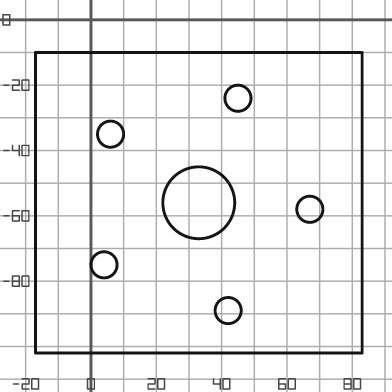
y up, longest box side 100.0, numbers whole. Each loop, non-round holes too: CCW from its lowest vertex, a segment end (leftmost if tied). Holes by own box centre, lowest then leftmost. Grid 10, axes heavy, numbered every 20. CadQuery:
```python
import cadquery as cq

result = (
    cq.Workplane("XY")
    .moveTo(-17.0, -102.0)
    .lineTo(83.0, -102.0)
    .lineTo(83.0, -10.0)
    .lineTo(-17.0, -10.0)
    .close()
    .moveTo(42.0, -89.0)
    .circle(4.0)
    .moveTo(4.0, -75.0)
    .circle(4.0)
    .moveTo(67.0, -58.0)
    .circle(4.0)
    .moveTo(33.0, -56.0)
    .circle(11.0)
    .moveTo(6.0, -35.0)
    .circle(4.0)
    .moveTo(45.0, -24.0)
    .circle(4.0)
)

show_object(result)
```